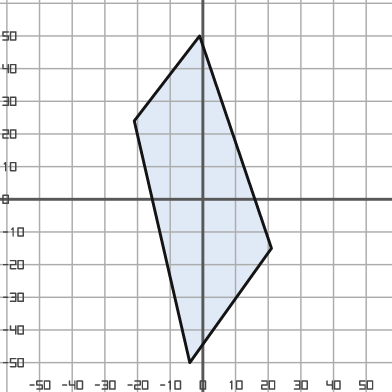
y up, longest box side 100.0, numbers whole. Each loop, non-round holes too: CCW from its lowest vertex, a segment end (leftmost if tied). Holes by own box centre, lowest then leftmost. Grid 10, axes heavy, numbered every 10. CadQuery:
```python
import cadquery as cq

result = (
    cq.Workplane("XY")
    .moveTo(-4.0, -50.0)
    .lineTo(21.0, -15.0)
    .lineTo(-1.0, 50.0)
    .lineTo(-21.0, 24.0)
    .close()
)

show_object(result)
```